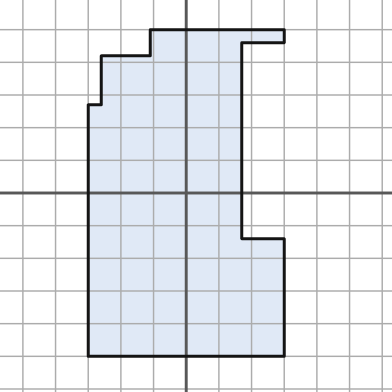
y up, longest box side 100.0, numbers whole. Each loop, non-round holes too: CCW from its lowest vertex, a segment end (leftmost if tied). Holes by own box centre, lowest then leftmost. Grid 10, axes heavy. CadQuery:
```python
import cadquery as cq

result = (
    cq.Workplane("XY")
    .moveTo(-30.0, -50.0)
    .lineTo(30.0, -50.0)
    .lineTo(30.0, -14.0)
    .lineTo(17.0, -14.0)
    .lineTo(17.0, 46.0)
    .lineTo(30.0, 46.0)
    .lineTo(30.0, 50.0)
    .lineTo(-11.0, 50.0)
    .lineTo(-11.0, 42.0)
    .lineTo(-26.0, 42.0)
    .lineTo(-26.0, 27.0)
    .lineTo(-30.0, 27.0)
    .close()
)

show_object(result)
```